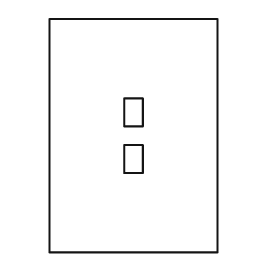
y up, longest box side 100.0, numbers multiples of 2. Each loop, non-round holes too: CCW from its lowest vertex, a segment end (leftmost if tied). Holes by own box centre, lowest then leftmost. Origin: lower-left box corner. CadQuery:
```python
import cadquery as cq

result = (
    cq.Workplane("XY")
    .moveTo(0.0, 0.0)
    .lineTo(72.0, 0.0)
    .lineTo(72.0, 100.0)
    .lineTo(0.0, 100.0)
    .close()
    .moveTo(32.0, 34.0)
    .lineTo(40.0, 34.0)
    .lineTo(40.0, 46.0)
    .lineTo(32.0, 46.0)
    .close()
    .moveTo(32.0, 54.0)
    .lineTo(40.0, 54.0)
    .lineTo(40.0, 66.0)
    .lineTo(32.0, 66.0)
    .close()
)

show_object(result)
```